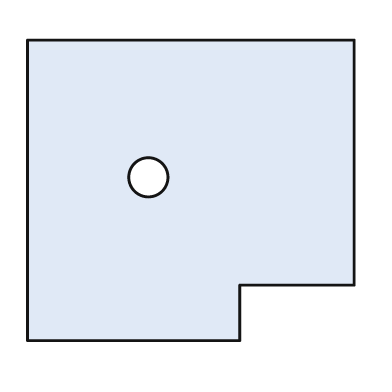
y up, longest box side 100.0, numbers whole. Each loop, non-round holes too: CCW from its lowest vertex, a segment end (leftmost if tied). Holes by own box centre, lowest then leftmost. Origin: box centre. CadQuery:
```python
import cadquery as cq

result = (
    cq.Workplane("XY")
    .moveTo(-50.0, -46.0)
    .lineTo(15.0, -46.0)
    .lineTo(15.0, -29.0)
    .lineTo(50.0, -29.0)
    .lineTo(50.0, 46.0)
    .lineTo(-50.0, 46.0)
    .close()
    .moveTo(-13.0, 4.0)
    .circle(6.0)
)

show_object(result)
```